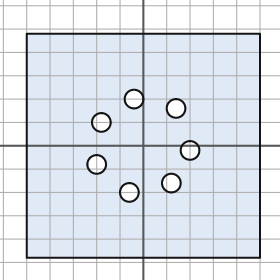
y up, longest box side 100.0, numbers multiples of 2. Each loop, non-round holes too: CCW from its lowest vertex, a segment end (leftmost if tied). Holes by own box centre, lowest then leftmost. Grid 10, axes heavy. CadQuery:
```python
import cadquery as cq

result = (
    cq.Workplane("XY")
    .moveTo(-50.0, -48.0)
    .lineTo(50.0, -48.0)
    .lineTo(50.0, 48.0)
    .lineTo(-50.0, 48.0)
    .close()
    .moveTo(-6.0, -20.0)
    .circle(4.0)
    .moveTo(12.0, -16.0)
    .circle(4.0)
    .moveTo(-20.0, -8.0)
    .circle(4.0)
    .moveTo(20.0, -2.0)
    .circle(4.0)
    .moveTo(-18.0, 10.0)
    .circle(4.0)
    .moveTo(14.0, 16.0)
    .circle(4.0)
    .moveTo(-4.0, 20.0)
    .circle(4.0)
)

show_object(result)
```